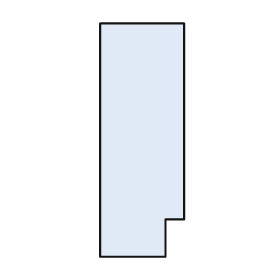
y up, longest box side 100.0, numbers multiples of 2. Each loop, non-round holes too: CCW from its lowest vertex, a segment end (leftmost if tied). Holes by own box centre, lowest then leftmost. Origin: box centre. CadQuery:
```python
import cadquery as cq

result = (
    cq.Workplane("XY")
    .moveTo(-18.0, -50.0)
    .lineTo(10.0, -50.0)
    .lineTo(10.0, -34.0)
    .lineTo(18.0, -34.0)
    .lineTo(18.0, 50.0)
    .lineTo(-18.0, 50.0)
    .close()
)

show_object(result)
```